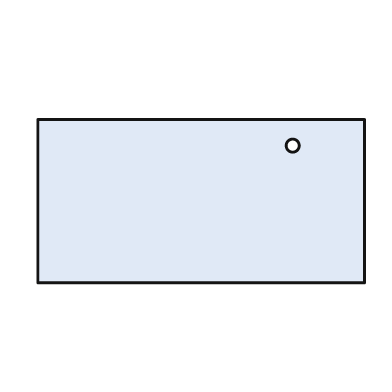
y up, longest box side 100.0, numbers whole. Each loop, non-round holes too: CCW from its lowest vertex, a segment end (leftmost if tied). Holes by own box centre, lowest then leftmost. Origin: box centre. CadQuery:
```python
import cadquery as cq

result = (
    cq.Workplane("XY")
    .moveTo(-50.0, -25.0)
    .lineTo(50.0, -25.0)
    .lineTo(50.0, 25.0)
    .lineTo(-50.0, 25.0)
    .close()
    .moveTo(28.0, 17.0)
    .circle(2.0)
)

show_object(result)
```